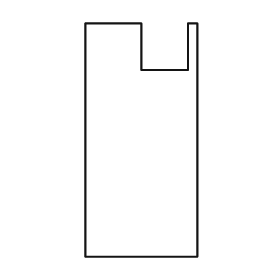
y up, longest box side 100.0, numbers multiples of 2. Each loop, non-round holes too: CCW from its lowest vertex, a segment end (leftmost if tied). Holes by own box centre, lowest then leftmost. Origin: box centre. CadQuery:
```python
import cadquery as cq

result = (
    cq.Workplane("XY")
    .moveTo(-24.0, -50.0)
    .lineTo(24.0, -50.0)
    .lineTo(24.0, 50.0)
    .lineTo(20.0, 50.0)
    .lineTo(20.0, 30.0)
    .lineTo(0.0, 30.0)
    .lineTo(0.0, 50.0)
    .lineTo(-24.0, 50.0)
    .close()
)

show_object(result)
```